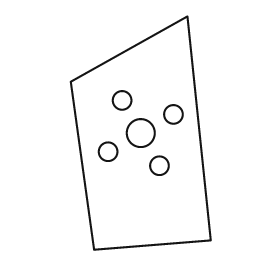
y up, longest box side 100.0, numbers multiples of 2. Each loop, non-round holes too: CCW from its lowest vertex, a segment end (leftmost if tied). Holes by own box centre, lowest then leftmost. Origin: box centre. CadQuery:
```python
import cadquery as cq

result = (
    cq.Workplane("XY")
    .moveTo(-20.0, -50.0)
    .lineTo(30.0, -46.0)
    .lineTo(20.0, 50.0)
    .lineTo(-30.0, 22.0)
    .close()
    .moveTo(8.0, -14.0)
    .circle(4.0)
    .moveTo(-14.0, -8.0)
    .circle(4.0)
    .moveTo(0.0, 0.0)
    .circle(6.0)
    .moveTo(14.0, 8.0)
    .circle(4.0)
    .moveTo(-8.0, 14.0)
    .circle(4.0)
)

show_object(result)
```